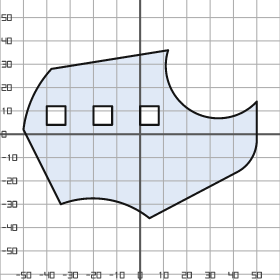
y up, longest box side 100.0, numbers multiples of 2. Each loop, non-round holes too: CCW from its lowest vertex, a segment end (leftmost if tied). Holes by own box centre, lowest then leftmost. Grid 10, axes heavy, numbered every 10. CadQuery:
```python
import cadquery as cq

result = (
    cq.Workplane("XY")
    .moveTo(4.0, -36.0)
    .lineTo(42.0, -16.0)
    .threePointArc((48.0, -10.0), (50.0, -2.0))
    .lineTo(50.0, 14.0)
    .threePointArc((22.0, 10.0), (12.0, 36.0))
    .lineTo(-38.0, 28.0)
    .threePointArc((-46.0, 16.0), (-50.0, 2.0))
    .lineTo(-34.0, -30.0)
    .threePointArc((-14.0, -28.0), (4.0, -36.0))
    .close()
    .moveTo(-40.0, 4.0)
    .lineTo(-32.0, 4.0)
    .lineTo(-32.0, 12.0)
    .lineTo(-40.0, 12.0)
    .close()
    .moveTo(-20.0, 4.0)
    .lineTo(-12.0, 4.0)
    .lineTo(-12.0, 12.0)
    .lineTo(-20.0, 12.0)
    .close()
    .moveTo(0.0, 4.0)
    .lineTo(8.0, 4.0)
    .lineTo(8.0, 12.0)
    .lineTo(0.0, 12.0)
    .close()
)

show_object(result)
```